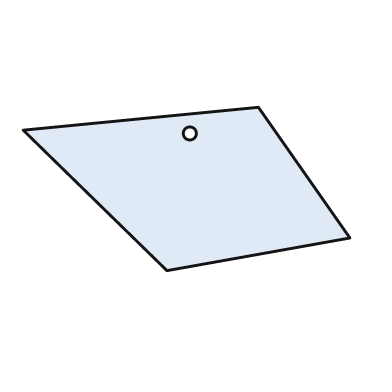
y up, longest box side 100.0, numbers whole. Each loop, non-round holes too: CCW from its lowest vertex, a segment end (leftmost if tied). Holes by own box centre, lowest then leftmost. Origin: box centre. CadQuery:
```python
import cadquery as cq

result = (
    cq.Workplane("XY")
    .moveTo(-6.0, -25.0)
    .lineTo(50.0, -15.0)
    .lineTo(22.0, 25.0)
    .lineTo(-50.0, 18.0)
    .close()
    .moveTo(1.0, 17.0)
    .circle(2.0)
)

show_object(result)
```